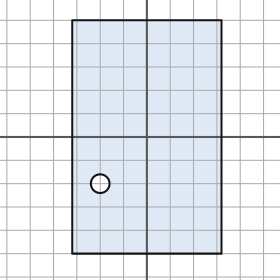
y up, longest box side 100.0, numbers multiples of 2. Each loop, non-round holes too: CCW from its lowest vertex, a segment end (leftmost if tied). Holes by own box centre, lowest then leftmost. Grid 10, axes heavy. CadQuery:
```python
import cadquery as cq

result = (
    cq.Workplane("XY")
    .moveTo(-32.0, -50.0)
    .lineTo(32.0, -50.0)
    .lineTo(32.0, 50.0)
    .lineTo(-32.0, 50.0)
    .close()
    .moveTo(-20.0, -20.0)
    .circle(4.0)
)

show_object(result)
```